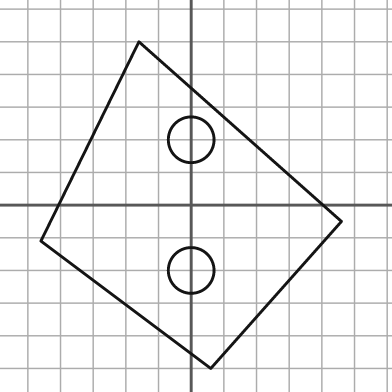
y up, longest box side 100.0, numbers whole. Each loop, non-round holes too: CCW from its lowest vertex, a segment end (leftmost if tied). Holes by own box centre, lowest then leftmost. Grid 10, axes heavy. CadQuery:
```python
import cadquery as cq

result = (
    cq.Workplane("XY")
    .moveTo(6.0, -50.0)
    .lineTo(46.0, -5.0)
    .lineTo(-16.0, 50.0)
    .lineTo(-46.0, -11.0)
    .close()
    .moveTo(0.0, -20.0)
    .circle(7.0)
    .moveTo(0.0, 20.0)
    .circle(7.0)
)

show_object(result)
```